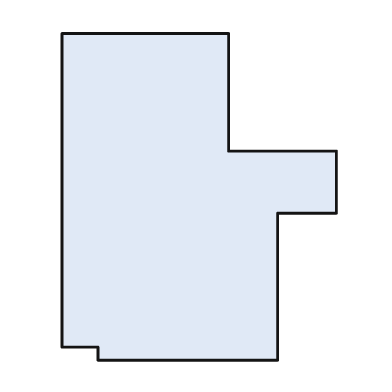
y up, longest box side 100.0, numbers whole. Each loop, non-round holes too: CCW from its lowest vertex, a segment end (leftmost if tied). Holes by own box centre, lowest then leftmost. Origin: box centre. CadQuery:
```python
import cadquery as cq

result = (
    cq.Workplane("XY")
    .moveTo(-31.0, -50.0)
    .lineTo(24.0, -50.0)
    .lineTo(24.0, -5.0)
    .lineTo(42.0, -5.0)
    .lineTo(42.0, 14.0)
    .lineTo(9.0, 14.0)
    .lineTo(9.0, 50.0)
    .lineTo(-42.0, 50.0)
    .lineTo(-42.0, -46.0)
    .lineTo(-31.0, -46.0)
    .close()
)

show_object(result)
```